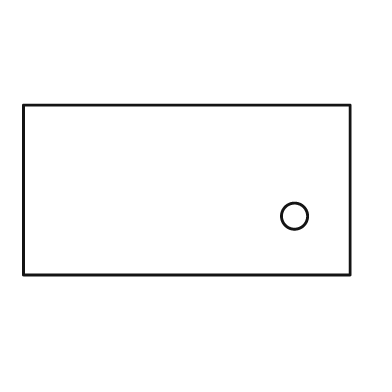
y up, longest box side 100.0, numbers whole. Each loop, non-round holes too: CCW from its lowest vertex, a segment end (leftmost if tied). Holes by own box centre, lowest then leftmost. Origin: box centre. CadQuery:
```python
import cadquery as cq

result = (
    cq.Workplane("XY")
    .moveTo(-50.0, -26.0)
    .lineTo(50.0, -26.0)
    .lineTo(50.0, 26.0)
    .lineTo(-50.0, 26.0)
    .close()
    .moveTo(33.0, -8.0)
    .circle(4.0)
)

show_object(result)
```